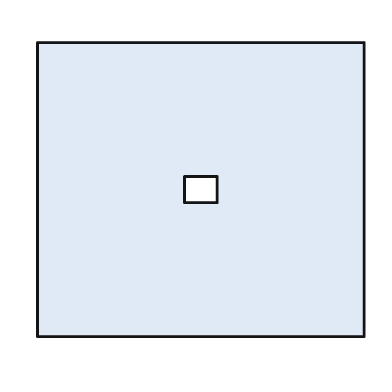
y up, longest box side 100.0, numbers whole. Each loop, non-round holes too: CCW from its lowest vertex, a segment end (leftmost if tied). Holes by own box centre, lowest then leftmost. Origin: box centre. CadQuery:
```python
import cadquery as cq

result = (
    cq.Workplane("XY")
    .moveTo(-50.0, -45.0)
    .lineTo(50.0, -45.0)
    .lineTo(50.0, 45.0)
    .lineTo(-50.0, 45.0)
    .close()
    .moveTo(-5.0, -4.0)
    .lineTo(5.0, -4.0)
    .lineTo(5.0, 4.0)
    .lineTo(-5.0, 4.0)
    .close()
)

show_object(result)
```